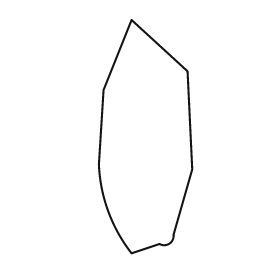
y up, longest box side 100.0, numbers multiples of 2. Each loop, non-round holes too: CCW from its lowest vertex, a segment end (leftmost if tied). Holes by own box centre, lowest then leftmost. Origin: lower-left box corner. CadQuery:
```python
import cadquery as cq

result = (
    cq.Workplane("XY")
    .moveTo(14.0, 0.0)
    .lineTo(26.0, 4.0)
    .threePointArc((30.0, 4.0), (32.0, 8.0))
    .lineTo(40.0, 36.0)
    .lineTo(38.0, 78.0)
    .lineTo(14.0, 100.0)
    .lineTo(2.0, 70.0)
    .lineTo(0.0, 38.0)
    .threePointArc((4.0, 18.0), (14.0, 0.0))
    .close()
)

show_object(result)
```